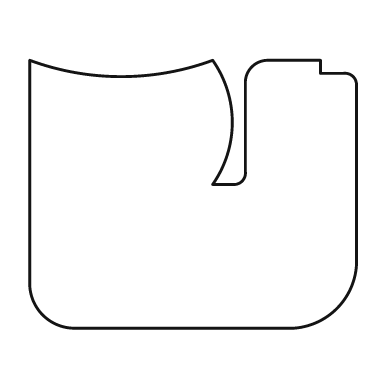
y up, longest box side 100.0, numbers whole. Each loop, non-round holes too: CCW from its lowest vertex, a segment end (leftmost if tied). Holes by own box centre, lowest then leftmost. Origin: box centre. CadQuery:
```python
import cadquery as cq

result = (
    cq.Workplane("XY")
    .moveTo(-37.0, -41.0)
    .lineTo(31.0, -41.0)
    .threePointArc((44.0, -35.0), (50.0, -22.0))
    .lineTo(50.0, 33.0)
    .threePointArc((49.0, 36.0), (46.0, 37.0))
    .lineTo(39.0, 37.0)
    .lineTo(39.0, 41.0)
    .lineTo(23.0, 41.0)
    .threePointArc((18.0, 39.0), (16.0, 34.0))
    .lineTo(16.0, 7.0)
    .threePointArc((15.0, 4.0), (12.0, 3.0))
    .lineTo(6.0, 3.0)
    .threePointArc((12.0, 22.0), (6.0, 41.0))
    .threePointArc((-22.0, 36.0), (-50.0, 41.0))
    .lineTo(-50.0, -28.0)
    .threePointArc((-46.0, -37.0), (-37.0, -41.0))
    .close()
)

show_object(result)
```